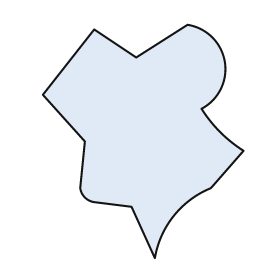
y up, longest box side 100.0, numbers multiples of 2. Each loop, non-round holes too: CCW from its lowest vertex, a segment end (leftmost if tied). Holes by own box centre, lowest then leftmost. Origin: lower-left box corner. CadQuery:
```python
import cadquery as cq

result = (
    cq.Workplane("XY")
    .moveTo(48.0, 0.0)
    .threePointArc((56.0, 18.0), (72.0, 30.0))
    .lineTo(86.0, 46.0)
    .threePointArc((76.0, 54.0), (68.0, 64.0))
    .threePointArc((78.0, 84.0), (62.0, 100.0))
    .lineTo(40.0, 86.0)
    .lineTo(22.0, 98.0)
    .lineTo(0.0, 70.0)
    .lineTo(18.0, 50.0)
    .lineTo(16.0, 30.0)
    .threePointArc((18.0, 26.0), (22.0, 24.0))
    .lineTo(38.0, 22.0)
    .close()
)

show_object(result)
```